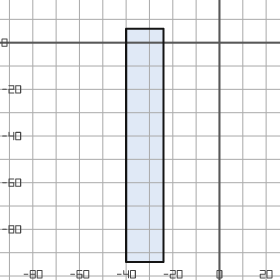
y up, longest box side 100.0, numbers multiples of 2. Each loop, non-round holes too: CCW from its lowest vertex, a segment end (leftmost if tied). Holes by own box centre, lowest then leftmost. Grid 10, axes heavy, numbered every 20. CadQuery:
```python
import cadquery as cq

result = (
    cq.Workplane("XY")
    .moveTo(-40.0, -94.0)
    .lineTo(-24.0, -94.0)
    .lineTo(-24.0, 6.0)
    .lineTo(-40.0, 6.0)
    .close()
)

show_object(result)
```